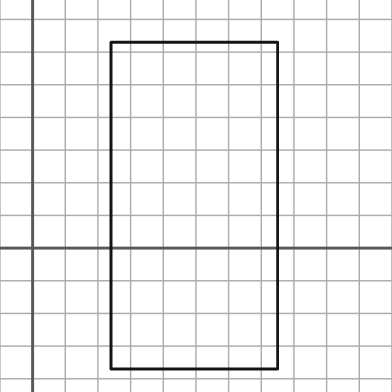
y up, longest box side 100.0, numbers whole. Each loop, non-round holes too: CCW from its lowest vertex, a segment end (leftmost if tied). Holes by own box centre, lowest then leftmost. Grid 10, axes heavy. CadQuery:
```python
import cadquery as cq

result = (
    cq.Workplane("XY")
    .moveTo(24.0, -37.0)
    .lineTo(75.0, -37.0)
    .lineTo(75.0, 63.0)
    .lineTo(24.0, 63.0)
    .close()
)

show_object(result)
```